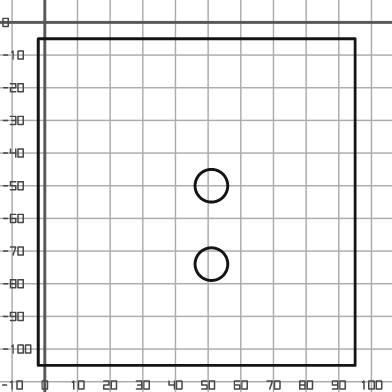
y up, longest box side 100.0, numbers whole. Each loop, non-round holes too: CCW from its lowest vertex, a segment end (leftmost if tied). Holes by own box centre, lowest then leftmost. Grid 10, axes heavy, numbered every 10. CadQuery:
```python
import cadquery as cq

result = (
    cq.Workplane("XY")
    .moveTo(-2.0, -105.0)
    .lineTo(95.0, -105.0)
    .lineTo(95.0, -5.0)
    .lineTo(-2.0, -5.0)
    .close()
    .moveTo(51.0, -74.0)
    .circle(5.0)
    .moveTo(51.0, -50.0)
    .circle(5.0)
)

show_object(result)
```